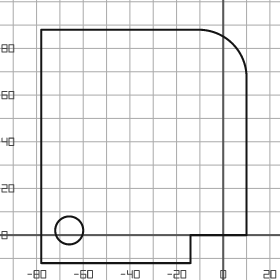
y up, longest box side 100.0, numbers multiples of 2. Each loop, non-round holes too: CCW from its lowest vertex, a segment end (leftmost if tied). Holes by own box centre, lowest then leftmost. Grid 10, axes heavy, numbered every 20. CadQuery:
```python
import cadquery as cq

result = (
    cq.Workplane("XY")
    .moveTo(-78.0, -12.0)
    .lineTo(-14.0, -12.0)
    .lineTo(-14.0, 0.0)
    .lineTo(10.0, 0.0)
    .lineTo(10.0, 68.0)
    .threePointArc((4.0, 82.0), (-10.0, 88.0))
    .lineTo(-78.0, 88.0)
    .close()
    .moveTo(-66.0, 2.0)
    .circle(6.0)
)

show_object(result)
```